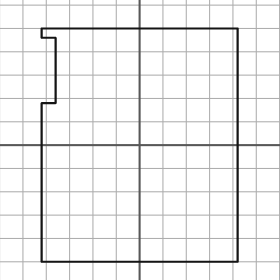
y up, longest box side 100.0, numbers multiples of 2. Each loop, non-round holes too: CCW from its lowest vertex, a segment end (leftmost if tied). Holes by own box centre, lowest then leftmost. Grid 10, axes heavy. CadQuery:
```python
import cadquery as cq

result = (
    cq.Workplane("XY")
    .moveTo(-42.0, -50.0)
    .lineTo(42.0, -50.0)
    .lineTo(42.0, 50.0)
    .lineTo(-42.0, 50.0)
    .lineTo(-42.0, 46.0)
    .lineTo(-36.0, 46.0)
    .lineTo(-36.0, 18.0)
    .lineTo(-42.0, 18.0)
    .close()
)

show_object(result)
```